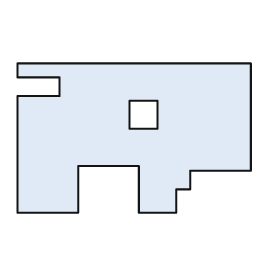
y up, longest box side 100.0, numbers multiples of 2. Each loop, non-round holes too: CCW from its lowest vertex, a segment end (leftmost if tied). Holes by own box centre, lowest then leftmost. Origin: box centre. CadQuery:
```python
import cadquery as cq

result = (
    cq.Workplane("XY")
    .moveTo(-50.0, -32.0)
    .lineTo(-24.0, -32.0)
    .lineTo(-24.0, -12.0)
    .lineTo(2.0, -12.0)
    .lineTo(2.0, -32.0)
    .lineTo(18.0, -32.0)
    .lineTo(18.0, -22.0)
    .lineTo(24.0, -22.0)
    .lineTo(24.0, -14.0)
    .lineTo(50.0, -14.0)
    .lineTo(50.0, 32.0)
    .lineTo(-50.0, 32.0)
    .lineTo(-50.0, 26.0)
    .lineTo(-32.0, 26.0)
    .lineTo(-32.0, 18.0)
    .lineTo(-50.0, 18.0)
    .close()
    .moveTo(-2.0, 4.0)
    .lineTo(10.0, 4.0)
    .lineTo(10.0, 16.0)
    .lineTo(-2.0, 16.0)
    .close()
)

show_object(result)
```